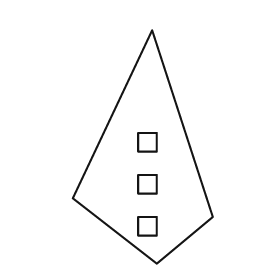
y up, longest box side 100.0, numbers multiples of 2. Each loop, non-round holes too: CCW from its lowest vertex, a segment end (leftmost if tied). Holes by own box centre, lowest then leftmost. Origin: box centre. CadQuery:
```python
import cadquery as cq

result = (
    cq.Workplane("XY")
    .moveTo(6.0, -50.0)
    .lineTo(30.0, -30.0)
    .lineTo(4.0, 50.0)
    .lineTo(-30.0, -22.0)
    .close()
    .moveTo(-2.0, -38.0)
    .lineTo(6.0, -38.0)
    .lineTo(6.0, -30.0)
    .lineTo(-2.0, -30.0)
    .close()
    .moveTo(-2.0, -20.0)
    .lineTo(6.0, -20.0)
    .lineTo(6.0, -12.0)
    .lineTo(-2.0, -12.0)
    .close()
    .moveTo(-2.0, -2.0)
    .lineTo(6.0, -2.0)
    .lineTo(6.0, 6.0)
    .lineTo(-2.0, 6.0)
    .close()
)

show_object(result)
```